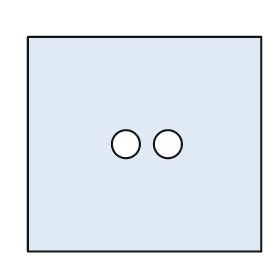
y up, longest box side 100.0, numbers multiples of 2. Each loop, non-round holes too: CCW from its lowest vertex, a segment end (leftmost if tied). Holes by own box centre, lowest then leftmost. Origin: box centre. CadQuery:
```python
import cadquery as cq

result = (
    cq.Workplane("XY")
    .moveTo(-50.0, -46.0)
    .lineTo(50.0, -46.0)
    .lineTo(50.0, 46.0)
    .lineTo(-50.0, 46.0)
    .close()
    .moveTo(-8.0, 0.0)
    .circle(6.0)
    .moveTo(10.0, 0.0)
    .circle(6.0)
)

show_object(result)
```